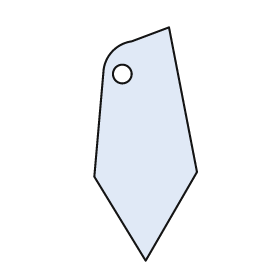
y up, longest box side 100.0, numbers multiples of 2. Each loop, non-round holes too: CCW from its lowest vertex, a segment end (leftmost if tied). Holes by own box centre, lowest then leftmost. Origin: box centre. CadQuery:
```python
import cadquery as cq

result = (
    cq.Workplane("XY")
    .moveTo(0.0, -50.0)
    .lineTo(22.0, -12.0)
    .lineTo(10.0, 50.0)
    .lineTo(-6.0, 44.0)
    .threePointArc((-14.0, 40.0), (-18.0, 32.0))
    .lineTo(-22.0, -14.0)
    .close()
    .moveTo(-10.0, 30.0)
    .circle(4.0)
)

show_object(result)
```